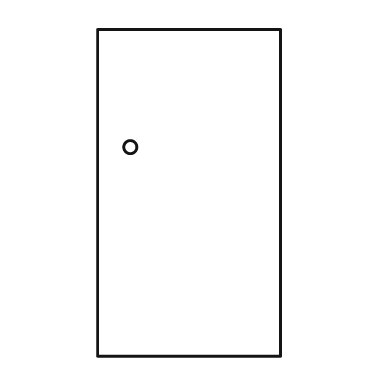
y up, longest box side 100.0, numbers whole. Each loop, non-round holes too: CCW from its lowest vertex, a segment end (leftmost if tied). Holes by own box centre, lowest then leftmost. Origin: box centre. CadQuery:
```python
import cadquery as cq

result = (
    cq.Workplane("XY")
    .moveTo(-28.0, -50.0)
    .lineTo(28.0, -50.0)
    .lineTo(28.0, 50.0)
    .lineTo(-28.0, 50.0)
    .close()
    .moveTo(-18.0, 14.0)
    .circle(2.0)
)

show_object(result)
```